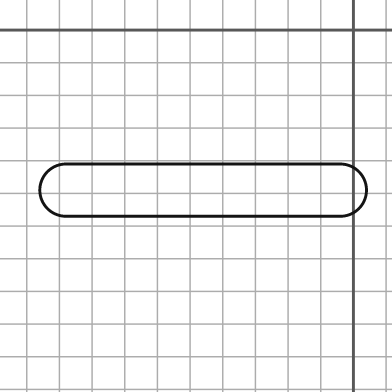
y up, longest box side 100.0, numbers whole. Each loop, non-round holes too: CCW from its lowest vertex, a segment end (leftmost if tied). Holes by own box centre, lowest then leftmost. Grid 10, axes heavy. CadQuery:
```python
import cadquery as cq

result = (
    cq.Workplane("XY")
    .moveTo(-88.0, -57.0)
    .lineTo(-4.0, -57.0)
    .threePointArc((4.0, -49.0), (-4.0, -41.0))
    .lineTo(-88.0, -41.0)
    .threePointArc((-96.0, -49.0), (-88.0, -57.0))
    .close()
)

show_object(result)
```